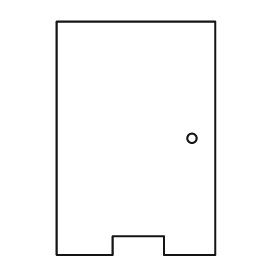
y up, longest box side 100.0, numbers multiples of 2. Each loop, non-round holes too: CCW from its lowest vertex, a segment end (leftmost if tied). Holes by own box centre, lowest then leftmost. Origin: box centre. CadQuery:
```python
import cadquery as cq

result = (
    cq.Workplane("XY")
    .moveTo(-34.0, -50.0)
    .lineTo(-10.0, -50.0)
    .lineTo(-10.0, -42.0)
    .lineTo(12.0, -42.0)
    .lineTo(12.0, -50.0)
    .lineTo(34.0, -50.0)
    .lineTo(34.0, 50.0)
    .lineTo(-34.0, 50.0)
    .close()
    .moveTo(24.0, 0.0)
    .circle(2.0)
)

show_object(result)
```